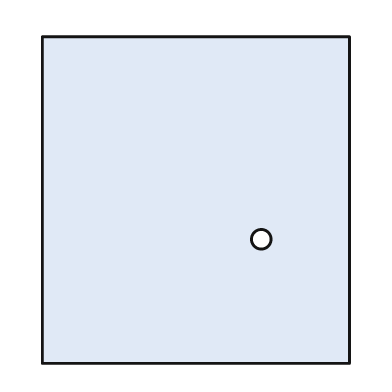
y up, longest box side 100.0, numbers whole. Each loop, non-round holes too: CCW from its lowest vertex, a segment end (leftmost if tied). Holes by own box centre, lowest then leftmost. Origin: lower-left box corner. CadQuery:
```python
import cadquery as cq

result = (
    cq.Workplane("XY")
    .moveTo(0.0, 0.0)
    .lineTo(94.0, 0.0)
    .lineTo(94.0, 100.0)
    .lineTo(0.0, 100.0)
    .close()
    .moveTo(67.0, 38.0)
    .circle(3.0)
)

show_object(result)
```